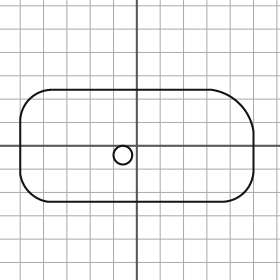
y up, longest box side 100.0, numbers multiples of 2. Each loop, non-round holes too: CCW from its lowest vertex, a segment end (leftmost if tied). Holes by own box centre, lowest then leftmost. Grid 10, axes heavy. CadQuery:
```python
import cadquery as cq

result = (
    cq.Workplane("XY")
    .moveTo(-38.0, -24.0)
    .lineTo(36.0, -24.0)
    .threePointArc((46.0, -20.0), (50.0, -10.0))
    .lineTo(50.0, 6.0)
    .threePointArc((44.0, 18.0), (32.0, 24.0))
    .lineTo(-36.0, 24.0)
    .threePointArc((-46.0, 20.0), (-50.0, 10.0))
    .lineTo(-50.0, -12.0)
    .threePointArc((-46.0, -20.0), (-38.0, -24.0))
    .close()
    .moveTo(-6.0, -4.0)
    .circle(4.0)
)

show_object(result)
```